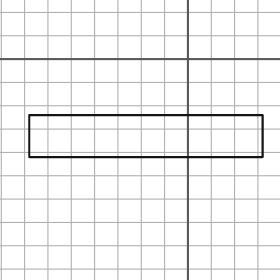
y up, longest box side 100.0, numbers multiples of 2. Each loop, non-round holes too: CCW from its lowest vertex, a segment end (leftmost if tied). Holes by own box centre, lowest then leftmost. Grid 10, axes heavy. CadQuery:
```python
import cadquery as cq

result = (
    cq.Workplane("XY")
    .moveTo(-68.0, -42.0)
    .lineTo(32.0, -42.0)
    .lineTo(32.0, -24.0)
    .lineTo(-68.0, -24.0)
    .close()
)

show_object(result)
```